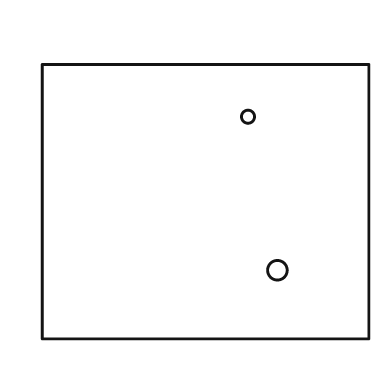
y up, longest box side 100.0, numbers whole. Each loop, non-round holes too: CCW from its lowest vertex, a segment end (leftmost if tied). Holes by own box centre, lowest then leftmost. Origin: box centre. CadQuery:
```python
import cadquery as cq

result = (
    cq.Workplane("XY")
    .moveTo(-50.0, -42.0)
    .lineTo(50.0, -42.0)
    .lineTo(50.0, 42.0)
    .lineTo(-50.0, 42.0)
    .close()
    .moveTo(22.0, -21.0)
    .circle(3.0)
    .moveTo(13.0, 26.0)
    .circle(2.0)
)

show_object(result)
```